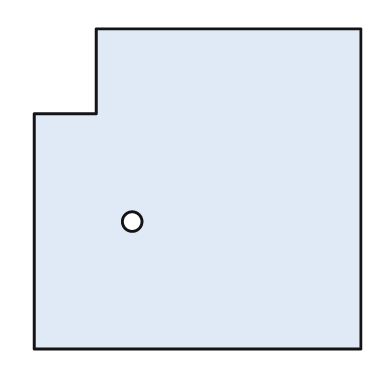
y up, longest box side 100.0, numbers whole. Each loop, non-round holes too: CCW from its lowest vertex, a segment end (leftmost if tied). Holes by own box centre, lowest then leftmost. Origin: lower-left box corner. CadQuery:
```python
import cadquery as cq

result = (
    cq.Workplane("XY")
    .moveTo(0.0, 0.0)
    .lineTo(100.0, 0.0)
    .lineTo(100.0, 98.0)
    .lineTo(19.0, 98.0)
    .lineTo(19.0, 72.0)
    .lineTo(0.0, 72.0)
    .close()
    .moveTo(30.0, 39.0)
    .circle(3.0)
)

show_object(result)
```